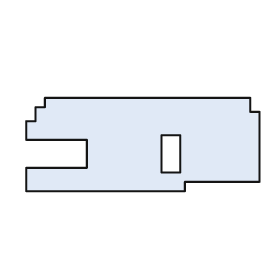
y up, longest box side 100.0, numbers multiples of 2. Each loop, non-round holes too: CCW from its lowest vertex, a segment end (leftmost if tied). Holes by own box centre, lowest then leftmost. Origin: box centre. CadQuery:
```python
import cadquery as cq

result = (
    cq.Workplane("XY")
    .moveTo(-50.0, -20.0)
    .lineTo(18.0, -20.0)
    .lineTo(18.0, -16.0)
    .lineTo(50.0, -16.0)
    .lineTo(50.0, 14.0)
    .lineTo(46.0, 14.0)
    .lineTo(46.0, 20.0)
    .lineTo(-42.0, 20.0)
    .lineTo(-42.0, 16.0)
    .lineTo(-46.0, 16.0)
    .lineTo(-46.0, 10.0)
    .lineTo(-50.0, 10.0)
    .lineTo(-50.0, 2.0)
    .lineTo(-24.0, 2.0)
    .lineTo(-24.0, -10.0)
    .lineTo(-50.0, -10.0)
    .close()
    .moveTo(8.0, -12.0)
    .lineTo(16.0, -12.0)
    .lineTo(16.0, 4.0)
    .lineTo(8.0, 4.0)
    .close()
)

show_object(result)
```